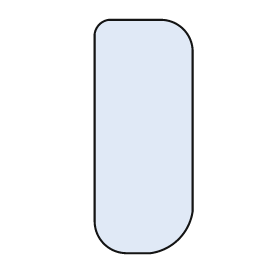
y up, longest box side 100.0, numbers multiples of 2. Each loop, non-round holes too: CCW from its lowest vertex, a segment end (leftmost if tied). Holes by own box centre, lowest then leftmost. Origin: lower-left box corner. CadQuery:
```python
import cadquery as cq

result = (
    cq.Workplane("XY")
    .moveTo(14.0, 0.0)
    .lineTo(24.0, 0.0)
    .threePointArc((36.0, 6.0), (42.0, 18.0))
    .lineTo(42.0, 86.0)
    .threePointArc((38.0, 96.0), (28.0, 100.0))
    .lineTo(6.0, 100.0)
    .threePointArc((2.0, 98.0), (0.0, 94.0))
    .lineTo(0.0, 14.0)
    .threePointArc((4.0, 4.0), (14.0, 0.0))
    .close()
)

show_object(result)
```